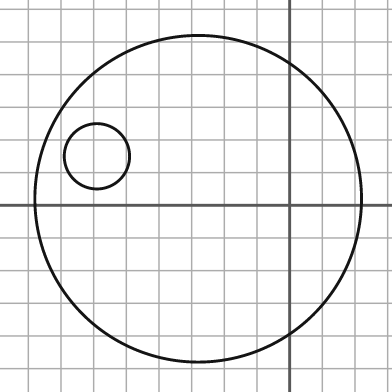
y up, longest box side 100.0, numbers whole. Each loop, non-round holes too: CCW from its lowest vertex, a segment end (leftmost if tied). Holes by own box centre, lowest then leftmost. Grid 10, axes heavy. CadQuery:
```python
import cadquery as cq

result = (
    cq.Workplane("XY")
    .moveTo(-28.0, 2.0)
    .circle(50.0)
    .moveTo(-59.0, 15.0)
    .circle(10.0)
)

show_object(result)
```